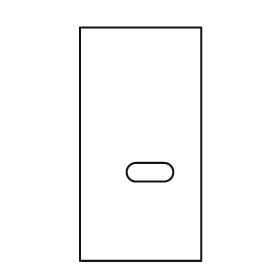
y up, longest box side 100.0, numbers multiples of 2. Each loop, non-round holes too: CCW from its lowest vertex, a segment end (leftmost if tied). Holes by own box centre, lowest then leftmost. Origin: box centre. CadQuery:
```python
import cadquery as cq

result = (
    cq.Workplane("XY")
    .moveTo(-26.0, -50.0)
    .lineTo(26.0, -50.0)
    .lineTo(26.0, 50.0)
    .lineTo(-26.0, 50.0)
    .close()
    .moveTo(-2.0, -16.0)
    .lineTo(10.0, -16.0)
    .threePointArc((14.0, -12.0), (10.0, -8.0))
    .lineTo(-2.0, -8.0)
    .threePointArc((-6.0, -12.0), (-2.0, -16.0))
    .close()
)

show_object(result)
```